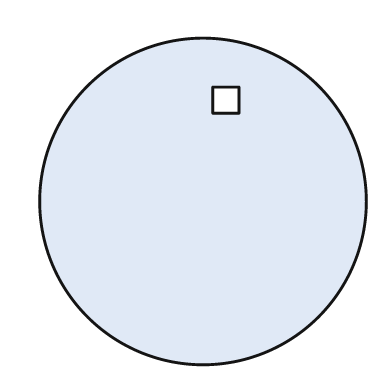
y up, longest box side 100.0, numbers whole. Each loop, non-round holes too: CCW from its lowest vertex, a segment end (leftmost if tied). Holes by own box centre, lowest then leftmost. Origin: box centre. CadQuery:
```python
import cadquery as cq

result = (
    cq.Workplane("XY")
    .moveTo(0.0, 0.0)
    .circle(50.0)
    .moveTo(3.0, 27.0)
    .lineTo(11.0, 27.0)
    .lineTo(11.0, 35.0)
    .lineTo(3.0, 35.0)
    .close()
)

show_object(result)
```